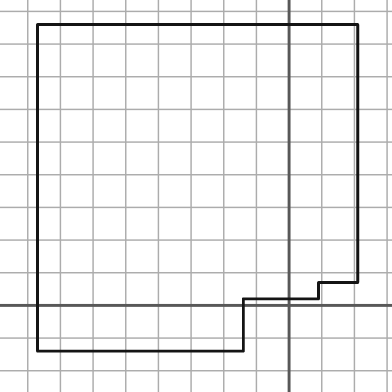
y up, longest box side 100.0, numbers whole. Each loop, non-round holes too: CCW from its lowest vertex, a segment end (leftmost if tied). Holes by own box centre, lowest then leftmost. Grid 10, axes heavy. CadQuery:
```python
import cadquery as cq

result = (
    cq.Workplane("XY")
    .moveTo(-77.0, -14.0)
    .lineTo(-14.0, -14.0)
    .lineTo(-14.0, 2.0)
    .lineTo(9.0, 2.0)
    .lineTo(9.0, 7.0)
    .lineTo(21.0, 7.0)
    .lineTo(21.0, 86.0)
    .lineTo(-77.0, 86.0)
    .close()
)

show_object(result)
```